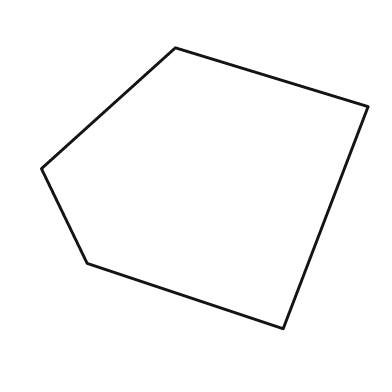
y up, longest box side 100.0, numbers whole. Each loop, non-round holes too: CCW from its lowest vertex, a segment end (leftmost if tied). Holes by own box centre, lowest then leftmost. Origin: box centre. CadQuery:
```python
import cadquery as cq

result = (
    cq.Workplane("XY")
    .moveTo(24.0, -43.0)
    .lineTo(50.0, 25.0)
    .lineTo(-9.0, 43.0)
    .lineTo(-50.0, 6.0)
    .lineTo(-36.0, -23.0)
    .close()
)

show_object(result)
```